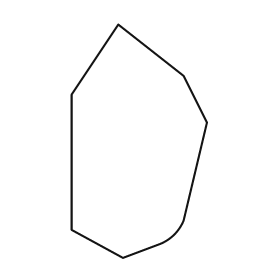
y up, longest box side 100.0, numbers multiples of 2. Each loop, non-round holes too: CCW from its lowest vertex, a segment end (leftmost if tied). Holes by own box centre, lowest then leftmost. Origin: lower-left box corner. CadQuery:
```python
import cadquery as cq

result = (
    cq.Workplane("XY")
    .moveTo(22.0, 0.0)
    .lineTo(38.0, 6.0)
    .threePointArc((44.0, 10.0), (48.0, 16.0))
    .lineTo(58.0, 58.0)
    .lineTo(48.0, 78.0)
    .lineTo(20.0, 100.0)
    .lineTo(0.0, 70.0)
    .lineTo(0.0, 12.0)
    .close()
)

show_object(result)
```